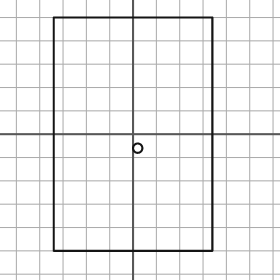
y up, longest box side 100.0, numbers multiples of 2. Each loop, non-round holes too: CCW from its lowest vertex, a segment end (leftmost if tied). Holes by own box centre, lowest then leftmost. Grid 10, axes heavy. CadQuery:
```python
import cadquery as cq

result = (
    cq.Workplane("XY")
    .moveTo(-34.0, -50.0)
    .lineTo(34.0, -50.0)
    .lineTo(34.0, 50.0)
    .lineTo(-34.0, 50.0)
    .close()
    .moveTo(2.0, -6.0)
    .circle(2.0)
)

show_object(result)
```